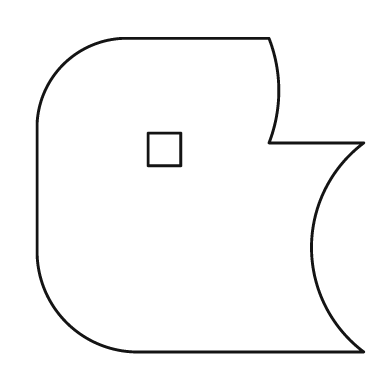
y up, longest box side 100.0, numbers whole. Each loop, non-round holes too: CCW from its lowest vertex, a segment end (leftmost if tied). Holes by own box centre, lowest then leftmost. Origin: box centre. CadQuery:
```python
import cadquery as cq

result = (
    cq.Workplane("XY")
    .moveTo(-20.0, -48.0)
    .lineTo(50.0, -48.0)
    .threePointArc((34.0, -16.0), (50.0, 16.0))
    .lineTo(21.0, 16.0)
    .threePointArc((24.0, 32.0), (21.0, 48.0))
    .lineTo(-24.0, 48.0)
    .threePointArc((-42.0, 40.0), (-50.0, 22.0))
    .lineTo(-50.0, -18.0)
    .threePointArc((-41.0, -39.0), (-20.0, -48.0))
    .close()
    .moveTo(-16.0, 9.0)
    .lineTo(-6.0, 9.0)
    .lineTo(-6.0, 19.0)
    .lineTo(-16.0, 19.0)
    .close()
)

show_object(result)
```